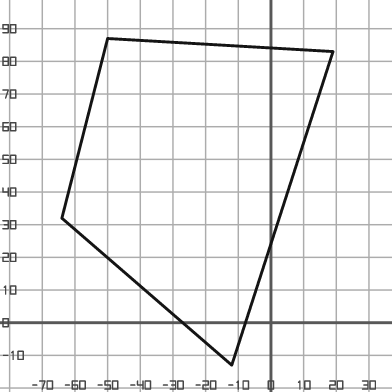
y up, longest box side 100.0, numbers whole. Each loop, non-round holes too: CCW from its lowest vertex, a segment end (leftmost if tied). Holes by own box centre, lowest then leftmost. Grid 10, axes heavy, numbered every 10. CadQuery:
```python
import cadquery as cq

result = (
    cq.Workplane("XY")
    .moveTo(-12.0, -13.0)
    .lineTo(19.0, 83.0)
    .lineTo(-50.0, 87.0)
    .lineTo(-64.0, 32.0)
    .close()
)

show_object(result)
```